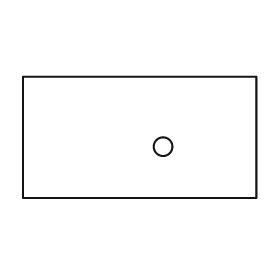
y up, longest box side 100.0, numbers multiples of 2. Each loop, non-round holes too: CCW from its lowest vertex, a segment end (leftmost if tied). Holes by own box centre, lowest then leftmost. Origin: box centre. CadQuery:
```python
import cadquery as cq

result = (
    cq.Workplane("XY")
    .moveTo(-50.0, -26.0)
    .lineTo(50.0, -26.0)
    .lineTo(50.0, 26.0)
    .lineTo(-50.0, 26.0)
    .close()
    .moveTo(10.0, -4.0)
    .circle(4.0)
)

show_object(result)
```